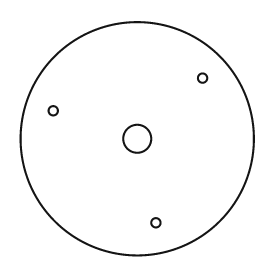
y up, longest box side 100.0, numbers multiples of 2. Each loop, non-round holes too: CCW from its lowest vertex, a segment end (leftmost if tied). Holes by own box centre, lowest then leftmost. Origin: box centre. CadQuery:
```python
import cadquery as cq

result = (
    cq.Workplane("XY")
    .moveTo(0.0, 0.0)
    .circle(50.0)
    .moveTo(8.0, -36.0)
    .circle(2.0)
    .moveTo(0.0, 0.0)
    .circle(6.0)
    .moveTo(-36.0, 12.0)
    .circle(2.0)
    .moveTo(28.0, 26.0)
    .circle(2.0)
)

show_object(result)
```